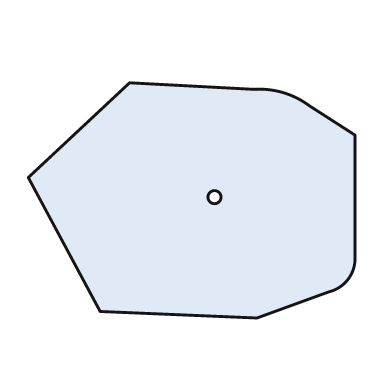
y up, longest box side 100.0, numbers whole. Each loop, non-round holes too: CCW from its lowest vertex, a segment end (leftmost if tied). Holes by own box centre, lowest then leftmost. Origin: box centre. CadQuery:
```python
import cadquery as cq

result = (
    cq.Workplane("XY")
    .moveTo(20.0, -36.0)
    .lineTo(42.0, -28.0)
    .threePointArc((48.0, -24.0), (50.0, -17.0))
    .lineTo(50.0, 20.0)
    .lineTo(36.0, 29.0)
    .threePointArc((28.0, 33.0), (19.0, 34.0))
    .lineTo(-19.0, 36.0)
    .lineTo(-50.0, 7.0)
    .lineTo(-28.0, -34.0)
    .close()
    .moveTo(7.0, 1.0)
    .circle(2.0)
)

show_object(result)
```